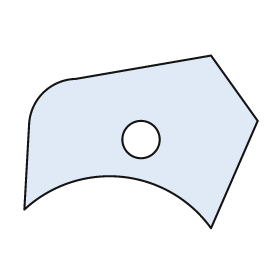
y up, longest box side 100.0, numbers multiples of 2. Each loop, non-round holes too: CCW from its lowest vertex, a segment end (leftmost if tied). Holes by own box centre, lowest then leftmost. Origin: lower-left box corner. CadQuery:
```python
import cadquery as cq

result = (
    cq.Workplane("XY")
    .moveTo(80.0, 0.0)
    .lineTo(100.0, 46.0)
    .lineTo(80.0, 74.0)
    .lineTo(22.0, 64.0)
    .threePointArc((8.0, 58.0), (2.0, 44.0))
    .lineTo(0.0, 8.0)
    .threePointArc((42.0, 22.0), (80.0, 0.0))
    .close()
    .moveTo(50.0, 38.0)
    .circle(8.0)
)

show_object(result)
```